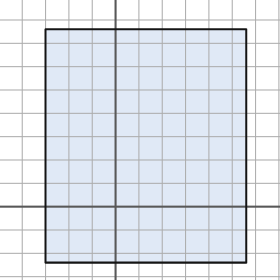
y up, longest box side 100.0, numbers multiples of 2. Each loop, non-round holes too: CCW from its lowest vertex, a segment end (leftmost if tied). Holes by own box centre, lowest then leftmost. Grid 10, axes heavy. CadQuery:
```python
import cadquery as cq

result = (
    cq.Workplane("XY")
    .moveTo(-30.0, -24.0)
    .lineTo(56.0, -24.0)
    .lineTo(56.0, 76.0)
    .lineTo(-30.0, 76.0)
    .close()
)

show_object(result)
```